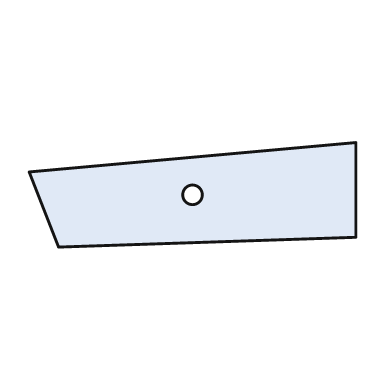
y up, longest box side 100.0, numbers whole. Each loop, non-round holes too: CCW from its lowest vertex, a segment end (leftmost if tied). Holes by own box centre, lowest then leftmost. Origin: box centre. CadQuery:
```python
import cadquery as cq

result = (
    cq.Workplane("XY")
    .moveTo(-41.0, -16.0)
    .lineTo(50.0, -13.0)
    .lineTo(50.0, 16.0)
    .lineTo(-50.0, 7.0)
    .close()
    .moveTo(0.0, 0.0)
    .circle(3.0)
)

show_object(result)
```